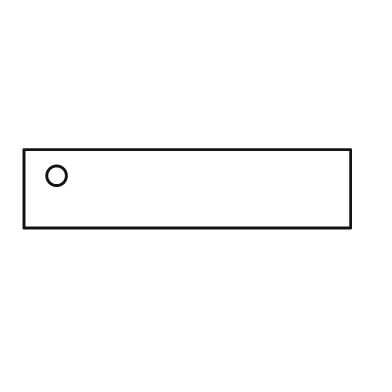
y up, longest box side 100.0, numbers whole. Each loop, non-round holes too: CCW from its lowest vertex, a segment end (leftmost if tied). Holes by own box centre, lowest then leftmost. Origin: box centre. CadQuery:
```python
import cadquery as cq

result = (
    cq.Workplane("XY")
    .moveTo(-50.0, -12.0)
    .lineTo(50.0, -12.0)
    .lineTo(50.0, 12.0)
    .lineTo(-50.0, 12.0)
    .close()
    .moveTo(-40.0, 4.0)
    .circle(3.0)
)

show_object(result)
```